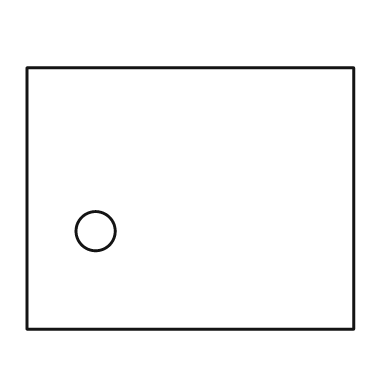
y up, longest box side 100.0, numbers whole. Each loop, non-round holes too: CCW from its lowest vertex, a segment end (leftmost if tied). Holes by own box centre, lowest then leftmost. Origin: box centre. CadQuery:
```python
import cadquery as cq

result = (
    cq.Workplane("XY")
    .moveTo(-50.0, -40.0)
    .lineTo(50.0, -40.0)
    .lineTo(50.0, 40.0)
    .lineTo(-50.0, 40.0)
    .close()
    .moveTo(-29.0, -10.0)
    .circle(6.0)
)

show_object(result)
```